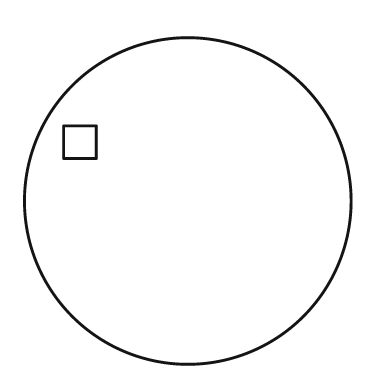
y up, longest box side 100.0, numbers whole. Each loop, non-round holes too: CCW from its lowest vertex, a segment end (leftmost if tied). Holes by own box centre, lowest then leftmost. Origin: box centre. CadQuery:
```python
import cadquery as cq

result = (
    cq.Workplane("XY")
    .moveTo(0.0, 0.0)
    .circle(50.0)
    .moveTo(-38.0, 13.0)
    .lineTo(-28.0, 13.0)
    .lineTo(-28.0, 23.0)
    .lineTo(-38.0, 23.0)
    .close()
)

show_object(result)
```